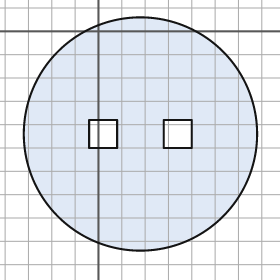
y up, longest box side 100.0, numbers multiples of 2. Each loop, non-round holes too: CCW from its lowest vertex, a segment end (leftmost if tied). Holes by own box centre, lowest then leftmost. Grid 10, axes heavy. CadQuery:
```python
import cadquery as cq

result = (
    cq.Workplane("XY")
    .moveTo(18.0, -44.0)
    .circle(50.0)
    .moveTo(-4.0, -50.0)
    .lineTo(8.0, -50.0)
    .lineTo(8.0, -38.0)
    .lineTo(-4.0, -38.0)
    .close()
    .moveTo(28.0, -50.0)
    .lineTo(40.0, -50.0)
    .lineTo(40.0, -38.0)
    .lineTo(28.0, -38.0)
    .close()
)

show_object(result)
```